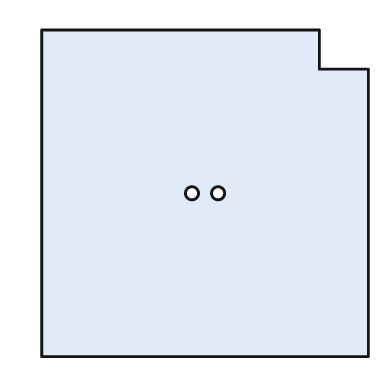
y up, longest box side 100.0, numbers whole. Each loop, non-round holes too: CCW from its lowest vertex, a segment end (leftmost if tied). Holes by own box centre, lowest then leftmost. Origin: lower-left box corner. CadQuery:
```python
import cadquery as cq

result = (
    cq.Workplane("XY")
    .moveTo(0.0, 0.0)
    .lineTo(100.0, 0.0)
    .lineTo(100.0, 88.0)
    .lineTo(85.0, 88.0)
    .lineTo(85.0, 100.0)
    .lineTo(0.0, 100.0)
    .close()
    .moveTo(46.0, 50.0)
    .circle(2.0)
    .moveTo(54.0, 50.0)
    .circle(2.0)
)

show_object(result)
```